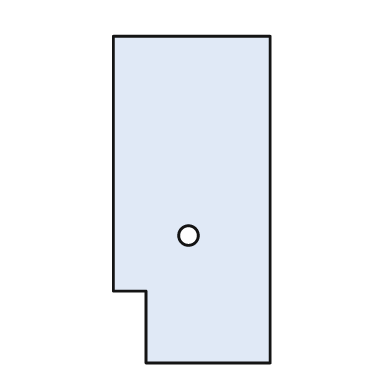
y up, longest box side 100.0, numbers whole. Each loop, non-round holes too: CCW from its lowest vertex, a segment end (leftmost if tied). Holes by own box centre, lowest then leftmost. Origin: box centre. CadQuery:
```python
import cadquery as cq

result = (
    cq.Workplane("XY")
    .moveTo(-14.0, -50.0)
    .lineTo(24.0, -50.0)
    .lineTo(24.0, 50.0)
    .lineTo(-24.0, 50.0)
    .lineTo(-24.0, -28.0)
    .lineTo(-14.0, -28.0)
    .close()
    .moveTo(-1.0, -11.0)
    .circle(3.0)
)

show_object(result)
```